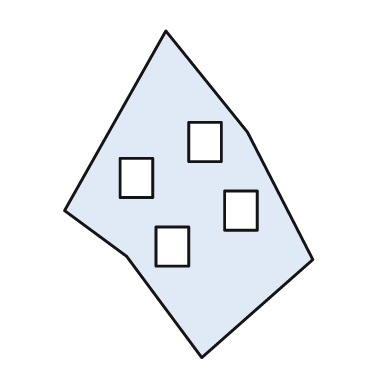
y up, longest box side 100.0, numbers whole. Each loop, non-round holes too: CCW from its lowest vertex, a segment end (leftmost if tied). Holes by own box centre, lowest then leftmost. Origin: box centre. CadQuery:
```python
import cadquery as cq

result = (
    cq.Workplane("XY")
    .moveTo(4.0, -50.0)
    .lineTo(38.0, -20.0)
    .lineTo(18.0, 19.0)
    .lineTo(-7.0, 50.0)
    .lineTo(-38.0, -5.0)
    .lineTo(-19.0, -19.0)
    .close()
    .moveTo(-10.0, -22.0)
    .lineTo(0.0, -22.0)
    .lineTo(0.0, -10.0)
    .lineTo(-10.0, -10.0)
    .close()
    .moveTo(11.0, -11.0)
    .lineTo(21.0, -11.0)
    .lineTo(21.0, 1.0)
    .lineTo(11.0, 1.0)
    .close()
    .moveTo(-21.0, -1.0)
    .lineTo(-11.0, -1.0)
    .lineTo(-11.0, 11.0)
    .lineTo(-21.0, 11.0)
    .close()
    .moveTo(0.0, 10.0)
    .lineTo(10.0, 10.0)
    .lineTo(10.0, 22.0)
    .lineTo(0.0, 22.0)
    .close()
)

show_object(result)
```